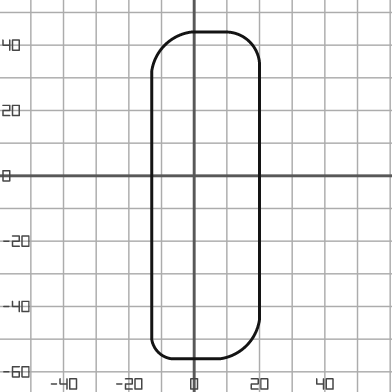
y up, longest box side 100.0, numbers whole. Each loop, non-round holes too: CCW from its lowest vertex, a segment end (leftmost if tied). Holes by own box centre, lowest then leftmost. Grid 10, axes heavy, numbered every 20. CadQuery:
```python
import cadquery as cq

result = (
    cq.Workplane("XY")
    .moveTo(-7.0, -56.0)
    .lineTo(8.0, -56.0)
    .threePointArc((16.0, -52.0), (20.0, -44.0))
    .lineTo(20.0, 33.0)
    .threePointArc((17.0, 41.0), (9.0, 44.0))
    .lineTo(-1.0, 44.0)
    .threePointArc((-9.0, 40.0), (-13.0, 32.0))
    .lineTo(-13.0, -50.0)
    .threePointArc((-11.0, -54.0), (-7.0, -56.0))
    .close()
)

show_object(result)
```